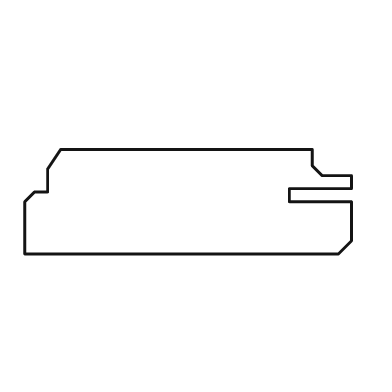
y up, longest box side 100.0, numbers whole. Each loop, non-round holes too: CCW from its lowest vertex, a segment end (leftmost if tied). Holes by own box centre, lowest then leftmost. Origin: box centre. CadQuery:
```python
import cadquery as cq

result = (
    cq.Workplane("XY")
    .moveTo(-50.0, -16.0)
    .lineTo(46.0, -16.0)
    .lineTo(50.0, -12.0)
    .lineTo(50.0, 0.0)
    .lineTo(31.0, 0.0)
    .lineTo(31.0, 4.0)
    .lineTo(50.0, 4.0)
    .lineTo(50.0, 8.0)
    .lineTo(41.0, 8.0)
    .lineTo(38.0, 11.0)
    .lineTo(38.0, 16.0)
    .lineTo(-39.0, 16.0)
    .lineTo(-43.0, 10.0)
    .lineTo(-43.0, 3.0)
    .lineTo(-47.0, 3.0)
    .lineTo(-50.0, 0.0)
    .close()
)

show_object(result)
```